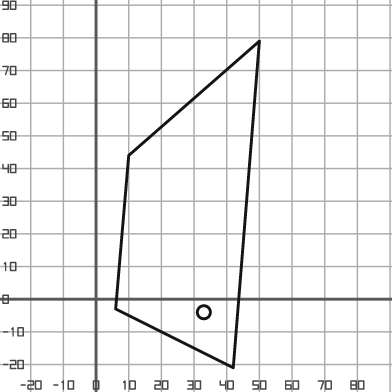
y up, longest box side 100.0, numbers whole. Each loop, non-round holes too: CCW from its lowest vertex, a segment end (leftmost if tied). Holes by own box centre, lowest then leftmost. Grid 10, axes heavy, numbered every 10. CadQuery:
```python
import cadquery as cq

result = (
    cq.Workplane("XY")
    .moveTo(42.0, -21.0)
    .lineTo(50.0, 79.0)
    .lineTo(10.0, 44.0)
    .lineTo(6.0, -3.0)
    .close()
    .moveTo(33.0, -4.0)
    .circle(2.0)
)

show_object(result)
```